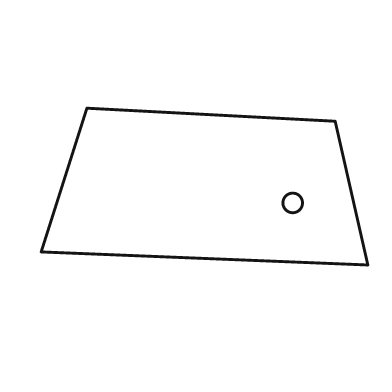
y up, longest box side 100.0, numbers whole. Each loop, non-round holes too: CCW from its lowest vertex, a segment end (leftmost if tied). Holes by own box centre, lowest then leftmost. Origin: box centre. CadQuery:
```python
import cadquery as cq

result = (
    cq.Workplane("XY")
    .moveTo(50.0, -24.0)
    .lineTo(40.0, 20.0)
    .lineTo(-36.0, 24.0)
    .lineTo(-50.0, -20.0)
    .close()
    .moveTo(27.0, -5.0)
    .circle(3.0)
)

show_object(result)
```